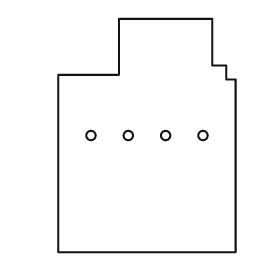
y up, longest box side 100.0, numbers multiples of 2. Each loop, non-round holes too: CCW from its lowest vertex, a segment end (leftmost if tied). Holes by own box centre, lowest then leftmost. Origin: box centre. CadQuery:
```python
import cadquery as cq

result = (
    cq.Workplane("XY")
    .moveTo(-38.0, -50.0)
    .lineTo(38.0, -50.0)
    .lineTo(38.0, 24.0)
    .lineTo(34.0, 24.0)
    .lineTo(34.0, 30.0)
    .lineTo(28.0, 30.0)
    .lineTo(28.0, 50.0)
    .lineTo(-12.0, 50.0)
    .lineTo(-12.0, 26.0)
    .lineTo(-38.0, 26.0)
    .close()
    .moveTo(-24.0, 0.0)
    .circle(2.0)
    .moveTo(-8.0, 0.0)
    .circle(2.0)
    .moveTo(8.0, 0.0)
    .circle(2.0)
    .moveTo(24.0, 0.0)
    .circle(2.0)
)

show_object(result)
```